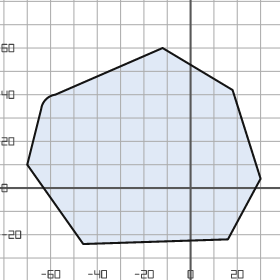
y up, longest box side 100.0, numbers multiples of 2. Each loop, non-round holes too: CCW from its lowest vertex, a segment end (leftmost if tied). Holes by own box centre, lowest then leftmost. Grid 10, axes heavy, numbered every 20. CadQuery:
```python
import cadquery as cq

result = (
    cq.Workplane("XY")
    .moveTo(-46.0, -24.0)
    .lineTo(16.0, -22.0)
    .lineTo(30.0, 4.0)
    .lineTo(18.0, 42.0)
    .lineTo(-12.0, 60.0)
    .lineTo(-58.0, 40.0)
    .threePointArc((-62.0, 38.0), (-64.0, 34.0))
    .lineTo(-70.0, 10.0)
    .close()
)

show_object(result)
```